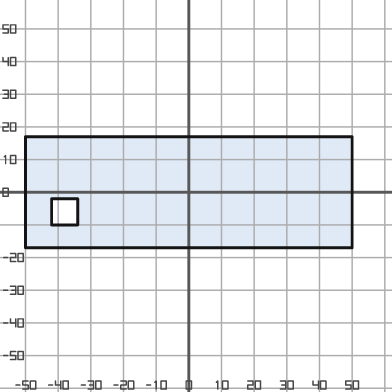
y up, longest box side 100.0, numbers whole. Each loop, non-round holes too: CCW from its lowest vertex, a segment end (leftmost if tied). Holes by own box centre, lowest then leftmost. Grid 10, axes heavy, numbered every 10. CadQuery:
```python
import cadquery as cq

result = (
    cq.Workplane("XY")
    .moveTo(-50.0, -17.0)
    .lineTo(50.0, -17.0)
    .lineTo(50.0, 17.0)
    .lineTo(-50.0, 17.0)
    .close()
    .moveTo(-42.0, -10.0)
    .lineTo(-34.0, -10.0)
    .lineTo(-34.0, -2.0)
    .lineTo(-42.0, -2.0)
    .close()
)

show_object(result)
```